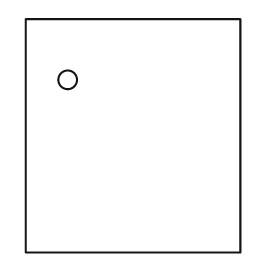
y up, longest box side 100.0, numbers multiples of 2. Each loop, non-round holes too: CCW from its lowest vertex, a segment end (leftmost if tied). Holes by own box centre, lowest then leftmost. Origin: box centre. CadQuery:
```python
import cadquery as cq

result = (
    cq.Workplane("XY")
    .moveTo(-46.0, -50.0)
    .lineTo(46.0, -50.0)
    .lineTo(46.0, 50.0)
    .lineTo(-46.0, 50.0)
    .close()
    .moveTo(-28.0, 24.0)
    .circle(4.0)
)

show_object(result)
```